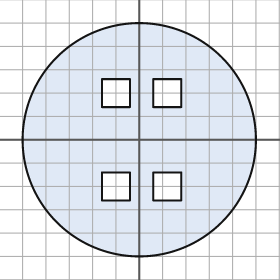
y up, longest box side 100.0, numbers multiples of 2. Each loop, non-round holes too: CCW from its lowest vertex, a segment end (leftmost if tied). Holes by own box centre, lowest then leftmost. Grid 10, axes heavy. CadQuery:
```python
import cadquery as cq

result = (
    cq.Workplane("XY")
    .moveTo(0.0, 0.0)
    .circle(50.0)
    .moveTo(-16.0, -26.0)
    .lineTo(-4.0, -26.0)
    .lineTo(-4.0, -14.0)
    .lineTo(-16.0, -14.0)
    .close()
    .moveTo(6.0, -26.0)
    .lineTo(18.0, -26.0)
    .lineTo(18.0, -14.0)
    .lineTo(6.0, -14.0)
    .close()
    .moveTo(-16.0, 14.0)
    .lineTo(-4.0, 14.0)
    .lineTo(-4.0, 26.0)
    .lineTo(-16.0, 26.0)
    .close()
    .moveTo(6.0, 14.0)
    .lineTo(18.0, 14.0)
    .lineTo(18.0, 26.0)
    .lineTo(6.0, 26.0)
    .close()
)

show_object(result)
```